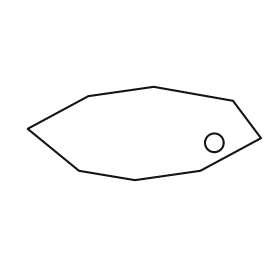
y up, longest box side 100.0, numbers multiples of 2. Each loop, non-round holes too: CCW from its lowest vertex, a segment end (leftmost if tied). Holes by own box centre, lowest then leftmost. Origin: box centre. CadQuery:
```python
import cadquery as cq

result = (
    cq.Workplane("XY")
    .moveTo(-4.0, -20.0)
    .lineTo(24.0, -16.0)
    .lineTo(50.0, -2.0)
    .lineTo(38.0, 14.0)
    .lineTo(4.0, 20.0)
    .lineTo(-24.0, 16.0)
    .lineTo(-50.0, 2.0)
    .lineTo(-28.0, -16.0)
    .close()
    .moveTo(30.0, -4.0)
    .circle(4.0)
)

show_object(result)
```